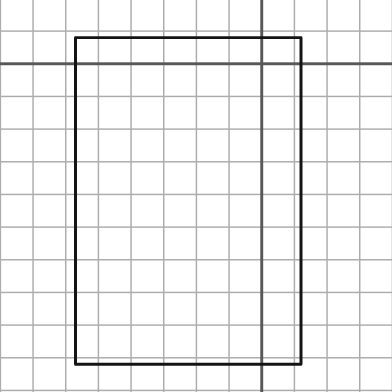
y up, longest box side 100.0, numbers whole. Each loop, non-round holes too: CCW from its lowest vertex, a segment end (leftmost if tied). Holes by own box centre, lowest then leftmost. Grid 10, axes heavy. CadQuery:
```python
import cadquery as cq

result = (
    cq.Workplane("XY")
    .moveTo(-57.0, -92.0)
    .lineTo(12.0, -92.0)
    .lineTo(12.0, 8.0)
    .lineTo(-57.0, 8.0)
    .close()
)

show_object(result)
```